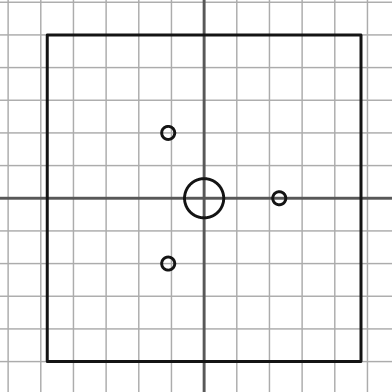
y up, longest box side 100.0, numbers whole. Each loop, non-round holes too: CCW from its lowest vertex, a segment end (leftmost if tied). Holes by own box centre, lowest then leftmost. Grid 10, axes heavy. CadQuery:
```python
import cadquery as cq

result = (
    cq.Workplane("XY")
    .moveTo(-48.0, -50.0)
    .lineTo(48.0, -50.0)
    .lineTo(48.0, 50.0)
    .lineTo(-48.0, 50.0)
    .close()
    .moveTo(-11.0, -20.0)
    .circle(2.0)
    .moveTo(0.0, 0.0)
    .circle(6.0)
    .moveTo(23.0, 0.0)
    .circle(2.0)
    .moveTo(-11.0, 20.0)
    .circle(2.0)
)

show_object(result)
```